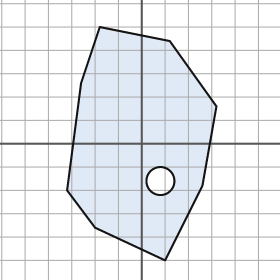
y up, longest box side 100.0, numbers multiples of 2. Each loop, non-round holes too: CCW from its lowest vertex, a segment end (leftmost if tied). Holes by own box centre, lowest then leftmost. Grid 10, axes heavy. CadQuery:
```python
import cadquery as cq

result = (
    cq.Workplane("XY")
    .moveTo(10.0, -50.0)
    .lineTo(26.0, -18.0)
    .lineTo(32.0, 16.0)
    .lineTo(12.0, 44.0)
    .lineTo(-18.0, 50.0)
    .lineTo(-26.0, 26.0)
    .lineTo(-32.0, -20.0)
    .lineTo(-20.0, -36.0)
    .close()
    .moveTo(8.0, -16.0)
    .circle(6.0)
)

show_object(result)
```